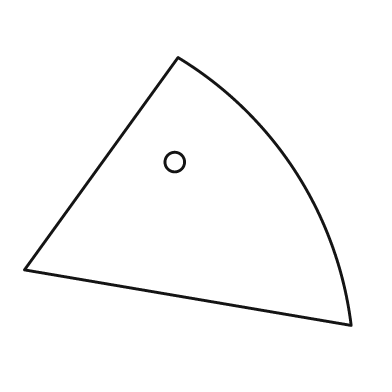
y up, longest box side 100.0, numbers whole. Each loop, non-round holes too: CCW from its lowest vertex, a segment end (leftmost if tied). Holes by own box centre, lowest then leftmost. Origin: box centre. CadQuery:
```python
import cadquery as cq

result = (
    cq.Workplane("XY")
    .moveTo(50.0, -41.0)
    .threePointArc((33.0, 6.0), (-3.0, 41.0))
    .lineTo(-50.0, -24.0)
    .close()
    .moveTo(-4.0, 9.0)
    .circle(3.0)
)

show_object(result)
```